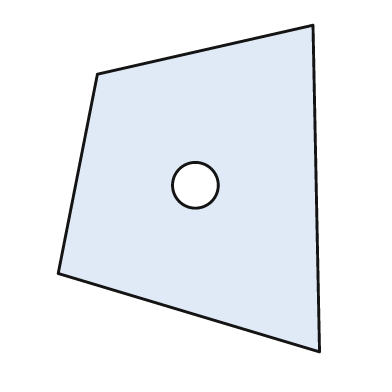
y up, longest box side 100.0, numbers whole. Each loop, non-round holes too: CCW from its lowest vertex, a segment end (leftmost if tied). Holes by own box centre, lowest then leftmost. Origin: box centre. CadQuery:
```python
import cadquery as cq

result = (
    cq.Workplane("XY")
    .moveTo(40.0, -50.0)
    .lineTo(38.0, 50.0)
    .lineTo(-28.0, 35.0)
    .lineTo(-40.0, -26.0)
    .close()
    .moveTo(2.0, 1.0)
    .circle(7.0)
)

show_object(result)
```